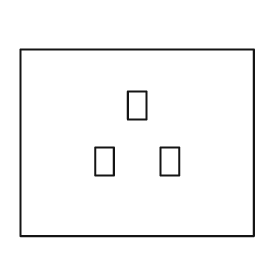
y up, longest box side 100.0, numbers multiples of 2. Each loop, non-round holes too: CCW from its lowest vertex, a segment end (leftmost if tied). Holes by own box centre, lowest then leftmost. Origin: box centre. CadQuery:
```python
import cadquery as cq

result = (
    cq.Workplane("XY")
    .moveTo(-50.0, -40.0)
    .lineTo(50.0, -40.0)
    .lineTo(50.0, 40.0)
    .lineTo(-50.0, 40.0)
    .close()
    .moveTo(-18.0, -14.0)
    .lineTo(-10.0, -14.0)
    .lineTo(-10.0, -2.0)
    .lineTo(-18.0, -2.0)
    .close()
    .moveTo(10.0, -14.0)
    .lineTo(18.0, -14.0)
    .lineTo(18.0, -2.0)
    .lineTo(10.0, -2.0)
    .close()
    .moveTo(-4.0, 10.0)
    .lineTo(4.0, 10.0)
    .lineTo(4.0, 22.0)
    .lineTo(-4.0, 22.0)
    .close()
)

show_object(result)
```